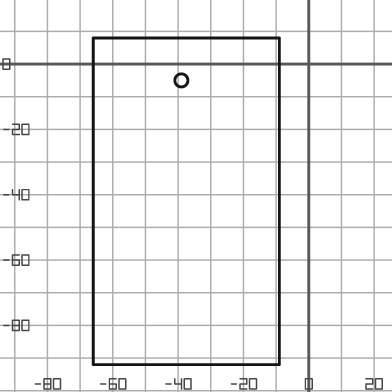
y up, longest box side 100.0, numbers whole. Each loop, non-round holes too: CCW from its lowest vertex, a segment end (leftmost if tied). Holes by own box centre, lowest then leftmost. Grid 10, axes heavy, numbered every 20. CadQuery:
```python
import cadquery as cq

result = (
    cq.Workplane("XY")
    .moveTo(-66.0, -92.0)
    .lineTo(-9.0, -92.0)
    .lineTo(-9.0, 8.0)
    .lineTo(-66.0, 8.0)
    .close()
    .moveTo(-39.0, -5.0)
    .circle(2.0)
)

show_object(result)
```